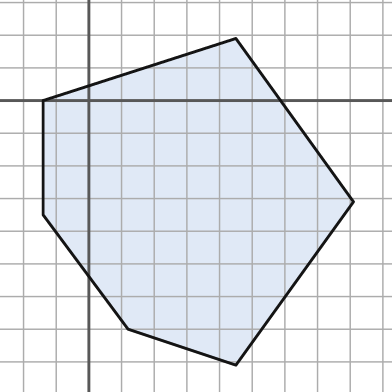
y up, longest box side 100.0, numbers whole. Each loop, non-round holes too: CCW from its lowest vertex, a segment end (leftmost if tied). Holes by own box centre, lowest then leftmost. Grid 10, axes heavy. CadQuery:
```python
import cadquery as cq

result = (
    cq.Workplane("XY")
    .moveTo(45.0, -81.0)
    .lineTo(81.0, -31.0)
    .lineTo(45.0, 19.0)
    .lineTo(-14.0, 0.0)
    .lineTo(-14.0, -35.0)
    .lineTo(12.0, -70.0)
    .close()
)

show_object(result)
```